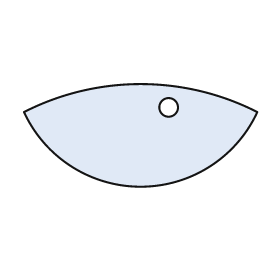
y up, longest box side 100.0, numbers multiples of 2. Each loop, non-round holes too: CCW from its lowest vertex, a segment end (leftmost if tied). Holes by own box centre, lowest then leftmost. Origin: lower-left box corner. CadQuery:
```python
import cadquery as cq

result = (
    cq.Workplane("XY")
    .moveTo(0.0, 32.0)
    .threePointArc((50.0, 0.0), (100.0, 32.0))
    .threePointArc((50.0, 44.0), (0.0, 32.0))
    .close()
    .moveTo(62.0, 34.0)
    .circle(4.0)
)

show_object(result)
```